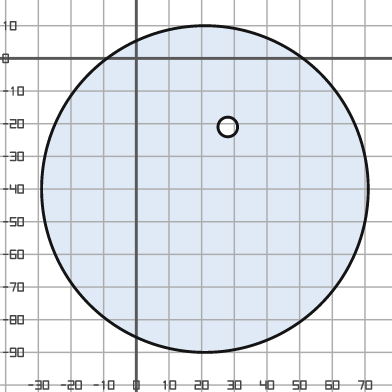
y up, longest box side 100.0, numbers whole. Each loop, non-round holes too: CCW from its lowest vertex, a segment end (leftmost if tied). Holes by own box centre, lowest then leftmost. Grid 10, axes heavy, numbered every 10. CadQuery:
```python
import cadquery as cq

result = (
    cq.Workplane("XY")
    .moveTo(21.0, -40.0)
    .circle(50.0)
    .moveTo(28.0, -21.0)
    .circle(3.0)
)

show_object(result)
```